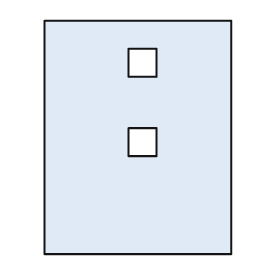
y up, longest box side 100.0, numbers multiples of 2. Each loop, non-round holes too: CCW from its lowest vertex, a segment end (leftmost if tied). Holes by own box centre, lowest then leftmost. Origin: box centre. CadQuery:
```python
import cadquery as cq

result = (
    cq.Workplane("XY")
    .moveTo(-40.0, -50.0)
    .lineTo(40.0, -50.0)
    .lineTo(40.0, 50.0)
    .lineTo(-40.0, 50.0)
    .close()
    .moveTo(-4.0, -8.0)
    .lineTo(8.0, -8.0)
    .lineTo(8.0, 4.0)
    .lineTo(-4.0, 4.0)
    .close()
    .moveTo(-4.0, 26.0)
    .lineTo(8.0, 26.0)
    .lineTo(8.0, 38.0)
    .lineTo(-4.0, 38.0)
    .close()
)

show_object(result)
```